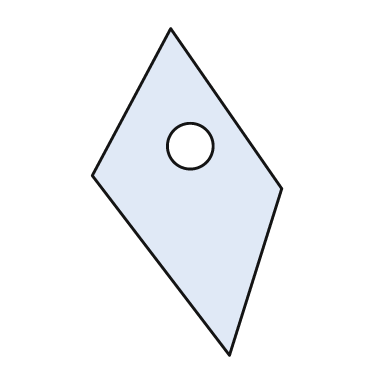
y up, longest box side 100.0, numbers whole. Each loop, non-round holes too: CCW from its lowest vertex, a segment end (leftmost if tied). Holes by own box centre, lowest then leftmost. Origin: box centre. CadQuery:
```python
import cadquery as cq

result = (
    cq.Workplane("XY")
    .moveTo(13.0, -50.0)
    .lineTo(29.0, 1.0)
    .lineTo(-5.0, 50.0)
    .lineTo(-29.0, 5.0)
    .close()
    .moveTo(1.0, 14.0)
    .circle(7.0)
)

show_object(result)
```